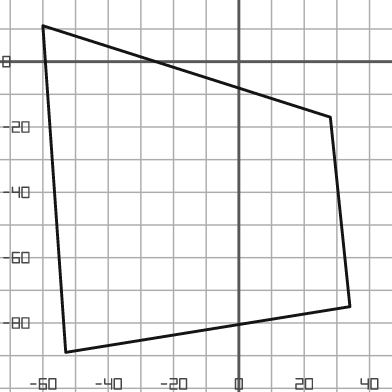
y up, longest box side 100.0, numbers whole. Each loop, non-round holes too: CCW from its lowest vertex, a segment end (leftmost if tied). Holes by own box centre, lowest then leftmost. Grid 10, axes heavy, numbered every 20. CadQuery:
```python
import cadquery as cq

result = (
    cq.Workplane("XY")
    .moveTo(-53.0, -89.0)
    .lineTo(34.0, -75.0)
    .lineTo(28.0, -17.0)
    .lineTo(-60.0, 11.0)
    .close()
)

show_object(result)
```